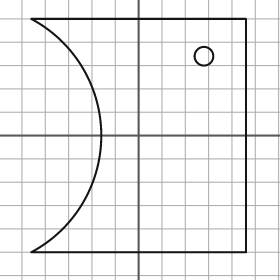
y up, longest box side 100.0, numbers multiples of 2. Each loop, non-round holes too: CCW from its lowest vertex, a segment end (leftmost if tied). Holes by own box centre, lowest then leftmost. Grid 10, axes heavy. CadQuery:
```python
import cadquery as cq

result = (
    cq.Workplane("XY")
    .moveTo(-46.0, -50.0)
    .lineTo(46.0, -50.0)
    .lineTo(46.0, 50.0)
    .lineTo(-46.0, 50.0)
    .threePointArc((-16.0, 0.0), (-46.0, -50.0))
    .close()
    .moveTo(28.0, 34.0)
    .circle(4.0)
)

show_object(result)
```